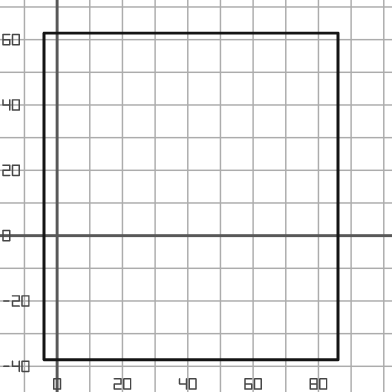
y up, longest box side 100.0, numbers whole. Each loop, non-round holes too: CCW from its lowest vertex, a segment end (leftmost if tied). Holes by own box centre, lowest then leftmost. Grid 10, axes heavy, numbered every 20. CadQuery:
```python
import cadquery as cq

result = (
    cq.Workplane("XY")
    .moveTo(-4.0, -38.0)
    .lineTo(86.0, -38.0)
    .lineTo(86.0, 62.0)
    .lineTo(-4.0, 62.0)
    .close()
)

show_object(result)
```